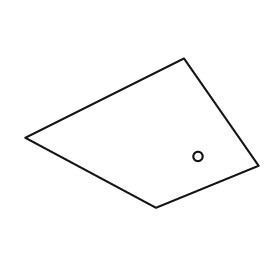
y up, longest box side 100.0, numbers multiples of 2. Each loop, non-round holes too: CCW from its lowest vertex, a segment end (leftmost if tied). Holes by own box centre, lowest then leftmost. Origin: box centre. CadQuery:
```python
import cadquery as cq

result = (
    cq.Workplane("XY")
    .moveTo(6.0, -32.0)
    .lineTo(50.0, -14.0)
    .lineTo(18.0, 32.0)
    .lineTo(-50.0, -2.0)
    .close()
    .moveTo(24.0, -10.0)
    .circle(2.0)
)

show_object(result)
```